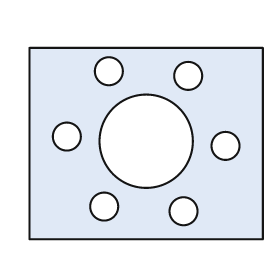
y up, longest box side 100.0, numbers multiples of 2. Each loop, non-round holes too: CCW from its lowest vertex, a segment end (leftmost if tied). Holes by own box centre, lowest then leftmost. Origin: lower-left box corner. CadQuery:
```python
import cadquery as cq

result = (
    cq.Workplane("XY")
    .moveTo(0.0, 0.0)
    .lineTo(100.0, 0.0)
    .lineTo(100.0, 82.0)
    .lineTo(0.0, 82.0)
    .close()
    .moveTo(66.0, 12.0)
    .circle(6.0)
    .moveTo(32.0, 14.0)
    .circle(6.0)
    .moveTo(84.0, 40.0)
    .circle(6.0)
    .moveTo(50.0, 42.0)
    .circle(20.0)
    .moveTo(16.0, 44.0)
    .circle(6.0)
    .moveTo(68.0, 70.0)
    .circle(6.0)
    .moveTo(34.0, 72.0)
    .circle(6.0)
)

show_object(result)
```